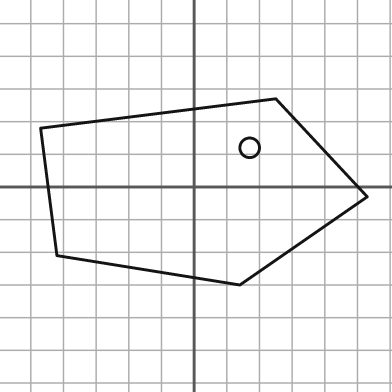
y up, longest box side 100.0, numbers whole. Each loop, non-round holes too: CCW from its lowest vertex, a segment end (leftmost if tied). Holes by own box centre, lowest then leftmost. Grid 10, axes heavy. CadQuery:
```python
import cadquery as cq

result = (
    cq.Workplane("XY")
    .moveTo(14.0, -30.0)
    .lineTo(53.0, -3.0)
    .lineTo(25.0, 27.0)
    .lineTo(-47.0, 18.0)
    .lineTo(-42.0, -21.0)
    .close()
    .moveTo(17.0, 12.0)
    .circle(3.0)
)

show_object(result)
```